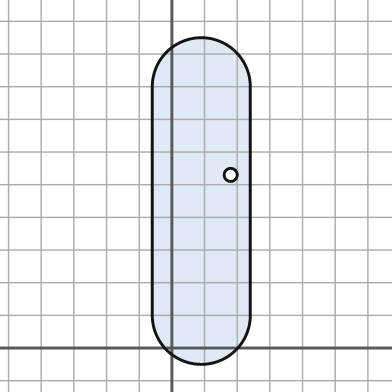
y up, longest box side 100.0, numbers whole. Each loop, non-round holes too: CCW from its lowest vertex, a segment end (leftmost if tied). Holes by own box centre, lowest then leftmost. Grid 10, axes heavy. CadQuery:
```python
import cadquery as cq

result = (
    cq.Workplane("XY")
    .moveTo(-6.0, 10.0)
    .threePointArc((9.0, -5.0), (24.0, 10.0))
    .lineTo(24.0, 80.0)
    .threePointArc((9.0, 95.0), (-6.0, 80.0))
    .close()
    .moveTo(18.0, 53.0)
    .circle(2.0)
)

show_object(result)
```